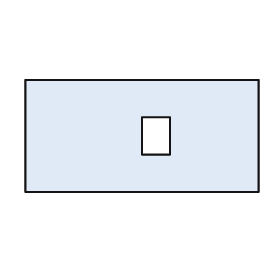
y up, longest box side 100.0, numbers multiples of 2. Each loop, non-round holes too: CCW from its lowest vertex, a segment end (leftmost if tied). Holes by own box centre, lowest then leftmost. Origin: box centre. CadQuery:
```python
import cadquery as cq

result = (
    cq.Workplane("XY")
    .moveTo(-50.0, -24.0)
    .lineTo(50.0, -24.0)
    .lineTo(50.0, 24.0)
    .lineTo(-50.0, 24.0)
    .close()
    .moveTo(0.0, -8.0)
    .lineTo(12.0, -8.0)
    .lineTo(12.0, 8.0)
    .lineTo(0.0, 8.0)
    .close()
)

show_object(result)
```